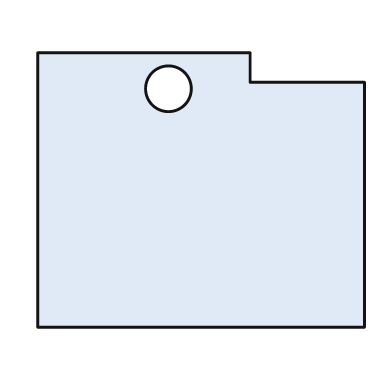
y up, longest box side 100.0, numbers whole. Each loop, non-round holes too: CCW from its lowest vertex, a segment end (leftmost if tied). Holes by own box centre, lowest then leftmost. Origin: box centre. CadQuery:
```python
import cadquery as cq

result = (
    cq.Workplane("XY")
    .moveTo(-50.0, -42.0)
    .lineTo(50.0, -42.0)
    .lineTo(50.0, 33.0)
    .lineTo(15.0, 33.0)
    .lineTo(15.0, 42.0)
    .lineTo(-50.0, 42.0)
    .close()
    .moveTo(-10.0, 31.0)
    .circle(7.0)
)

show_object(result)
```